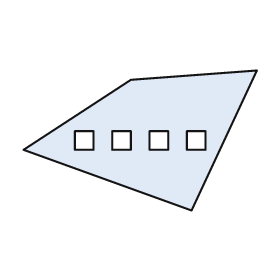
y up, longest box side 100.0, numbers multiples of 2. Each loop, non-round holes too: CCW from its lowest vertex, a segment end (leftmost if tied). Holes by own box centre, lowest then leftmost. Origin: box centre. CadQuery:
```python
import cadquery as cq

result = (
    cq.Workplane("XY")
    .moveTo(22.0, -30.0)
    .lineTo(50.0, 30.0)
    .lineTo(-4.0, 26.0)
    .lineTo(-50.0, -4.0)
    .close()
    .moveTo(-28.0, -4.0)
    .lineTo(-20.0, -4.0)
    .lineTo(-20.0, 4.0)
    .lineTo(-28.0, 4.0)
    .close()
    .moveTo(-12.0, -4.0)
    .lineTo(-4.0, -4.0)
    .lineTo(-4.0, 4.0)
    .lineTo(-12.0, 4.0)
    .close()
    .moveTo(4.0, -4.0)
    .lineTo(12.0, -4.0)
    .lineTo(12.0, 4.0)
    .lineTo(4.0, 4.0)
    .close()
    .moveTo(20.0, -4.0)
    .lineTo(28.0, -4.0)
    .lineTo(28.0, 4.0)
    .lineTo(20.0, 4.0)
    .close()
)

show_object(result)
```